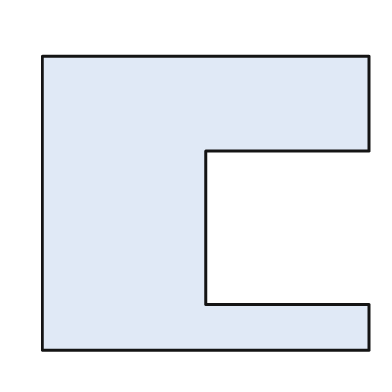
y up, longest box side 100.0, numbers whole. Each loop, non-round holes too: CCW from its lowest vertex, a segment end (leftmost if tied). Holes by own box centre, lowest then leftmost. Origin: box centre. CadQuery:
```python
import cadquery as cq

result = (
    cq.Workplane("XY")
    .moveTo(-50.0, -45.0)
    .lineTo(50.0, -45.0)
    .lineTo(50.0, -31.0)
    .lineTo(0.0, -31.0)
    .lineTo(0.0, 16.0)
    .lineTo(50.0, 16.0)
    .lineTo(50.0, 45.0)
    .lineTo(-50.0, 45.0)
    .close()
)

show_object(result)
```